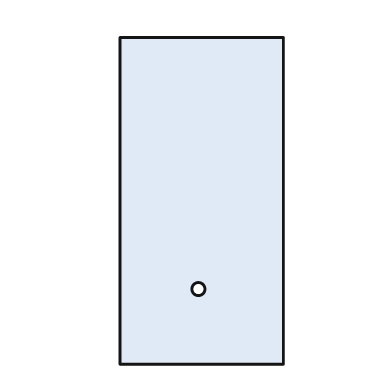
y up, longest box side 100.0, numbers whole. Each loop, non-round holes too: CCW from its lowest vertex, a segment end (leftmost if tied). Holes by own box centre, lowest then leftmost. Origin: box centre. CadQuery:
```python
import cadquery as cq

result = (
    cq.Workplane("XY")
    .moveTo(-25.0, -50.0)
    .lineTo(25.0, -50.0)
    .lineTo(25.0, 50.0)
    .lineTo(-25.0, 50.0)
    .close()
    .moveTo(-1.0, -27.0)
    .circle(2.0)
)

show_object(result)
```